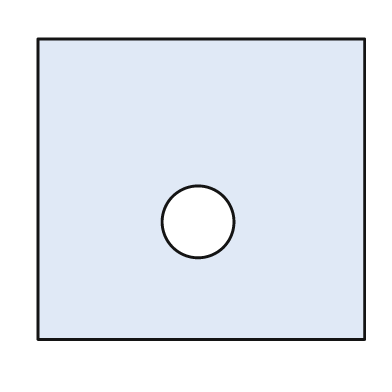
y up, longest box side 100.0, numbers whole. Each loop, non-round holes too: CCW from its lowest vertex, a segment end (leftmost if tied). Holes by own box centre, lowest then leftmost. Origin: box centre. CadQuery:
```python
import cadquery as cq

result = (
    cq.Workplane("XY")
    .moveTo(-50.0, -46.0)
    .lineTo(50.0, -46.0)
    .lineTo(50.0, 46.0)
    .lineTo(-50.0, 46.0)
    .close()
    .moveTo(-1.0, -10.0)
    .circle(11.0)
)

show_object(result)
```